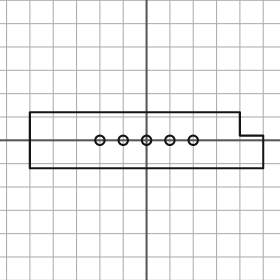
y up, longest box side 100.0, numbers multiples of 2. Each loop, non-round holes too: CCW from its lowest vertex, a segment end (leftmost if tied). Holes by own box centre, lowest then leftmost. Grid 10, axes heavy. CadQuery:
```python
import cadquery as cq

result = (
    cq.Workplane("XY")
    .moveTo(-50.0, -12.0)
    .lineTo(50.0, -12.0)
    .lineTo(50.0, 2.0)
    .lineTo(40.0, 2.0)
    .lineTo(40.0, 12.0)
    .lineTo(-50.0, 12.0)
    .close()
    .moveTo(-20.0, 0.0)
    .circle(2.0)
    .moveTo(-10.0, 0.0)
    .circle(2.0)
    .moveTo(0.0, 0.0)
    .circle(2.0)
    .moveTo(10.0, 0.0)
    .circle(2.0)
    .moveTo(20.0, 0.0)
    .circle(2.0)
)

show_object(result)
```